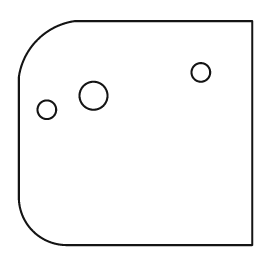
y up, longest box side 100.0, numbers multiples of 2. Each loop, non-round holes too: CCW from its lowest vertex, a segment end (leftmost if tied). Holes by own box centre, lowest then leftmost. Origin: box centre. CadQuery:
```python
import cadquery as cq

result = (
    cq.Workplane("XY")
    .moveTo(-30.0, -48.0)
    .lineTo(50.0, -48.0)
    .lineTo(50.0, 48.0)
    .lineTo(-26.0, 48.0)
    .threePointArc((-42.0, 40.0), (-50.0, 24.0))
    .lineTo(-50.0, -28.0)
    .threePointArc((-44.0, -42.0), (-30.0, -48.0))
    .close()
    .moveTo(-38.0, 10.0)
    .circle(4.0)
    .moveTo(-18.0, 16.0)
    .circle(6.0)
    .moveTo(28.0, 26.0)
    .circle(4.0)
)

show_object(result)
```